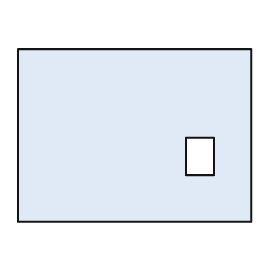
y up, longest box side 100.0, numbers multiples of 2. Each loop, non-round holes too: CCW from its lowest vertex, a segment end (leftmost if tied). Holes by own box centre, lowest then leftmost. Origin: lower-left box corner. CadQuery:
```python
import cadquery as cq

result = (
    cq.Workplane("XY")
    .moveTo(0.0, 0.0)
    .lineTo(100.0, 0.0)
    .lineTo(100.0, 74.0)
    .lineTo(0.0, 74.0)
    .close()
    .moveTo(72.0, 20.0)
    .lineTo(84.0, 20.0)
    .lineTo(84.0, 36.0)
    .lineTo(72.0, 36.0)
    .close()
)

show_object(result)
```